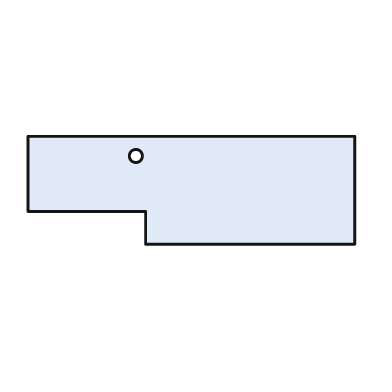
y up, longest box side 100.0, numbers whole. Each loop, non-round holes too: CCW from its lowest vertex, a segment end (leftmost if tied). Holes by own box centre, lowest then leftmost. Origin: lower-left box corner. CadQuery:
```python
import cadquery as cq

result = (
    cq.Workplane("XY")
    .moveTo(36.0, 0.0)
    .lineTo(100.0, 0.0)
    .lineTo(100.0, 33.0)
    .lineTo(0.0, 33.0)
    .lineTo(0.0, 10.0)
    .lineTo(36.0, 10.0)
    .close()
    .moveTo(33.0, 27.0)
    .circle(2.0)
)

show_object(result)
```